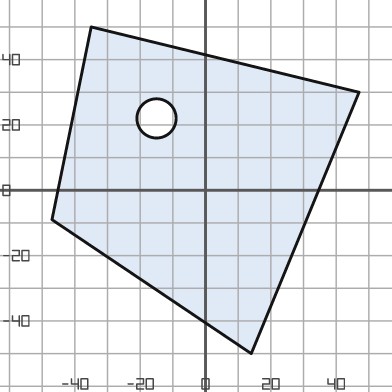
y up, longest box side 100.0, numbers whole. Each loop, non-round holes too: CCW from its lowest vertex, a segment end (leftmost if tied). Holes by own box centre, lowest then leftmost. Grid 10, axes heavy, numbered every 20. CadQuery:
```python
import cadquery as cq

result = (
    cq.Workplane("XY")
    .moveTo(14.0, -50.0)
    .lineTo(47.0, 30.0)
    .lineTo(-35.0, 50.0)
    .lineTo(-47.0, -9.0)
    .close()
    .moveTo(-15.0, 22.0)
    .circle(6.0)
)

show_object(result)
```